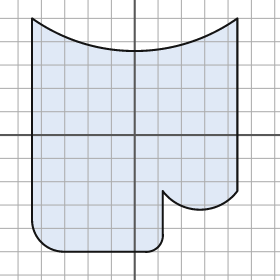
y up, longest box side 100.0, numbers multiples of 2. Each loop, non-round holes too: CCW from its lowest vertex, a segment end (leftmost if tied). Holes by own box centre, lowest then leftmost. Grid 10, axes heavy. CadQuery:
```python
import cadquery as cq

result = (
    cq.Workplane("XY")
    .moveTo(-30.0, -50.0)
    .lineTo(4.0, -50.0)
    .threePointArc((10.0, -48.0), (12.0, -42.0))
    .lineTo(12.0, -24.0)
    .threePointArc((28.0, -32.0), (44.0, -24.0))
    .lineTo(44.0, 50.0)
    .threePointArc((0.0, 36.0), (-44.0, 50.0))
    .lineTo(-44.0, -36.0)
    .threePointArc((-40.0, -46.0), (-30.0, -50.0))
    .close()
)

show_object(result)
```